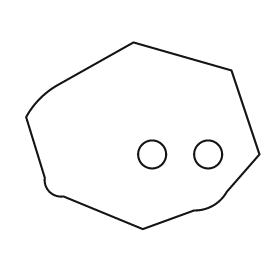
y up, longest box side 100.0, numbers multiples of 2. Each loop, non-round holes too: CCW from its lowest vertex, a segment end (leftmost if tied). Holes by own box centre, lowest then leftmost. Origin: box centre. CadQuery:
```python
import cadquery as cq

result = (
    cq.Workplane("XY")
    .moveTo(0.0, -40.0)
    .lineTo(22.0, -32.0)
    .threePointArc((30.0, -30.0), (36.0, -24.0))
    .lineTo(50.0, -8.0)
    .lineTo(38.0, 28.0)
    .lineTo(-4.0, 40.0)
    .lineTo(-36.0, 22.0)
    .threePointArc((-44.0, 16.0), (-50.0, 8.0))
    .lineTo(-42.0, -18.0)
    .threePointArc((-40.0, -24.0), (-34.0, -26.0))
    .close()
    .moveTo(4.0, -8.0)
    .circle(6.0)
    .moveTo(28.0, -8.0)
    .circle(6.0)
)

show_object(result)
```